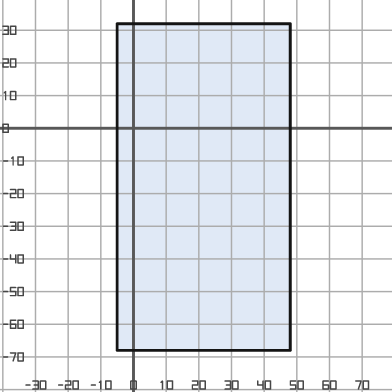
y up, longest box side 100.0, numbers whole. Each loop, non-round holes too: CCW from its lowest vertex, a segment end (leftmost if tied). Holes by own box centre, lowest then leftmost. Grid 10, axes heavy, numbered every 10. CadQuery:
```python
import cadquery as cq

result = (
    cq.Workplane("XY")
    .moveTo(-5.0, -68.0)
    .lineTo(48.0, -68.0)
    .lineTo(48.0, 32.0)
    .lineTo(-5.0, 32.0)
    .close()
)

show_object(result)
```